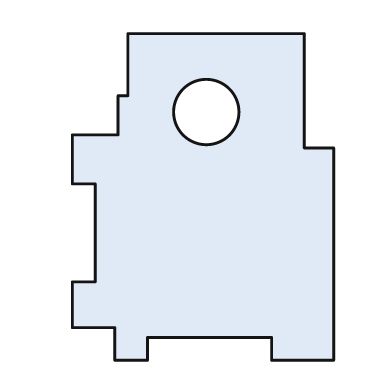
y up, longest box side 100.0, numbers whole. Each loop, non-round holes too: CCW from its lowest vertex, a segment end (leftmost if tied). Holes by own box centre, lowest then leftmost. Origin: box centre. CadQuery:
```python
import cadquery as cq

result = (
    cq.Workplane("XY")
    .moveTo(-27.0, -50.0)
    .lineTo(-17.0, -50.0)
    .lineTo(-17.0, -43.0)
    .lineTo(21.0, -43.0)
    .lineTo(21.0, -50.0)
    .lineTo(40.0, -50.0)
    .lineTo(40.0, 15.0)
    .lineTo(31.0, 15.0)
    .lineTo(31.0, 50.0)
    .lineTo(-23.0, 50.0)
    .lineTo(-23.0, 31.0)
    .lineTo(-26.0, 31.0)
    .lineTo(-26.0, 19.0)
    .lineTo(-40.0, 19.0)
    .lineTo(-40.0, 4.0)
    .lineTo(-33.0, 4.0)
    .lineTo(-33.0, -26.0)
    .lineTo(-40.0, -26.0)
    .lineTo(-40.0, -40.0)
    .lineTo(-27.0, -40.0)
    .close()
    .moveTo(1.0, 26.0)
    .circle(10.0)
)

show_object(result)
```